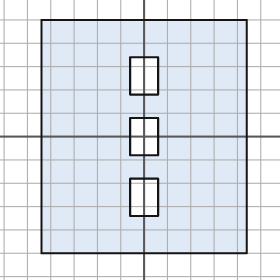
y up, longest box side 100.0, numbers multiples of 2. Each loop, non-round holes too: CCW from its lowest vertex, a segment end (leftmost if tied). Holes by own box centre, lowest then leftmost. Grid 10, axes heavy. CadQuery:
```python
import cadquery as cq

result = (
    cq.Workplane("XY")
    .moveTo(-44.0, -50.0)
    .lineTo(44.0, -50.0)
    .lineTo(44.0, 50.0)
    .lineTo(-44.0, 50.0)
    .close()
    .moveTo(-6.0, -34.0)
    .lineTo(6.0, -34.0)
    .lineTo(6.0, -18.0)
    .lineTo(-6.0, -18.0)
    .close()
    .moveTo(-6.0, -8.0)
    .lineTo(6.0, -8.0)
    .lineTo(6.0, 8.0)
    .lineTo(-6.0, 8.0)
    .close()
    .moveTo(-6.0, 18.0)
    .lineTo(6.0, 18.0)
    .lineTo(6.0, 34.0)
    .lineTo(-6.0, 34.0)
    .close()
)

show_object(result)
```